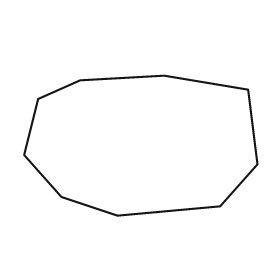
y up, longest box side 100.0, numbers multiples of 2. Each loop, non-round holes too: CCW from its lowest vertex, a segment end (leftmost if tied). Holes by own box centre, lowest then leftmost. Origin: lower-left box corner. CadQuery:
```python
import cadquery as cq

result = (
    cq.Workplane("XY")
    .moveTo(40.0, 0.0)
    .lineTo(84.0, 4.0)
    .lineTo(100.0, 22.0)
    .lineTo(96.0, 54.0)
    .lineTo(60.0, 60.0)
    .lineTo(24.0, 58.0)
    .lineTo(6.0, 50.0)
    .lineTo(0.0, 26.0)
    .lineTo(16.0, 8.0)
    .close()
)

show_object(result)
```